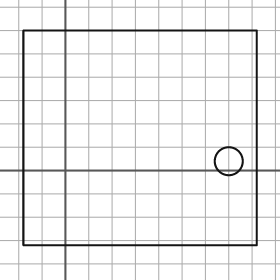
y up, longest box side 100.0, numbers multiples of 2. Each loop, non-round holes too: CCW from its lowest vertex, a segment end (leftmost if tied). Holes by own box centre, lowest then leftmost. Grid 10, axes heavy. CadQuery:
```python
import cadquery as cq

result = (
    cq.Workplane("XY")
    .moveTo(-18.0, -32.0)
    .lineTo(82.0, -32.0)
    .lineTo(82.0, 60.0)
    .lineTo(-18.0, 60.0)
    .close()
    .moveTo(70.0, 4.0)
    .circle(6.0)
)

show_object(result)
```